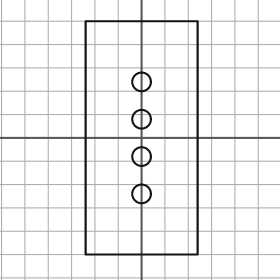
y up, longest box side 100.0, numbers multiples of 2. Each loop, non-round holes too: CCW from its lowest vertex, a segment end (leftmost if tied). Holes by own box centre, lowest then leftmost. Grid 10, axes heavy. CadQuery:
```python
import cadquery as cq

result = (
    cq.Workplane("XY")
    .moveTo(-24.0, -50.0)
    .lineTo(24.0, -50.0)
    .lineTo(24.0, 50.0)
    .lineTo(-24.0, 50.0)
    .close()
    .moveTo(0.0, -24.0)
    .circle(4.0)
    .moveTo(0.0, -8.0)
    .circle(4.0)
    .moveTo(0.0, 8.0)
    .circle(4.0)
    .moveTo(0.0, 24.0)
    .circle(4.0)
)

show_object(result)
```